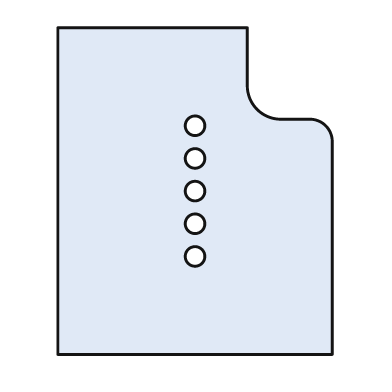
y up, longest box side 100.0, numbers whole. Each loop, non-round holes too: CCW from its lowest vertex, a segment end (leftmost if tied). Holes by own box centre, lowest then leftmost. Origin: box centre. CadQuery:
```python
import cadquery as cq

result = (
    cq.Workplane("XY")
    .moveTo(-42.0, -50.0)
    .lineTo(42.0, -50.0)
    .lineTo(42.0, 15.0)
    .threePointArc((40.0, 20.0), (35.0, 22.0))
    .lineTo(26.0, 22.0)
    .threePointArc((19.0, 25.0), (16.0, 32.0))
    .lineTo(16.0, 50.0)
    .lineTo(-42.0, 50.0)
    .close()
    .moveTo(0.0, -20.0)
    .circle(3.0)
    .moveTo(0.0, -10.0)
    .circle(3.0)
    .moveTo(0.0, 0.0)
    .circle(3.0)
    .moveTo(0.0, 10.0)
    .circle(3.0)
    .moveTo(0.0, 20.0)
    .circle(3.0)
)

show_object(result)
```